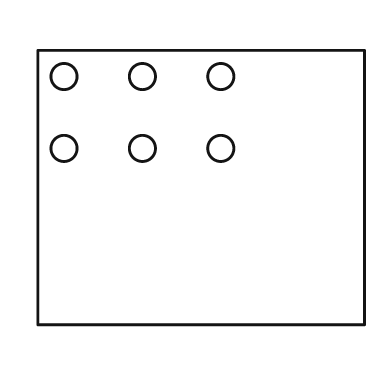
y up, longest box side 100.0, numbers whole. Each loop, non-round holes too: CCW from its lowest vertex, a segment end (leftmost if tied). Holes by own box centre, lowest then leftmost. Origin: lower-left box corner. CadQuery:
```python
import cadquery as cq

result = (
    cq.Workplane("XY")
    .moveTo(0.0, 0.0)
    .lineTo(100.0, 0.0)
    .lineTo(100.0, 84.0)
    .lineTo(0.0, 84.0)
    .close()
    .moveTo(8.0, 54.0)
    .circle(4.0)
    .moveTo(32.0, 54.0)
    .circle(4.0)
    .moveTo(56.0, 54.0)
    .circle(4.0)
    .moveTo(8.0, 76.0)
    .circle(4.0)
    .moveTo(32.0, 76.0)
    .circle(4.0)
    .moveTo(56.0, 76.0)
    .circle(4.0)
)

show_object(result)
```